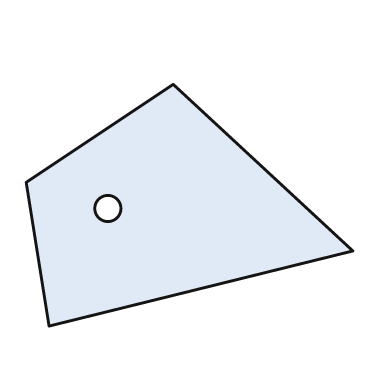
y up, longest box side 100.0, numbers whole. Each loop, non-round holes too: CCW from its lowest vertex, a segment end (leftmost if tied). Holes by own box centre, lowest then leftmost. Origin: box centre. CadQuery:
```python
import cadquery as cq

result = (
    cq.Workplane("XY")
    .moveTo(-43.0, -37.0)
    .lineTo(50.0, -14.0)
    .lineTo(-5.0, 37.0)
    .lineTo(-50.0, 7.0)
    .close()
    .moveTo(-25.0, -1.0)
    .circle(4.0)
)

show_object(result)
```